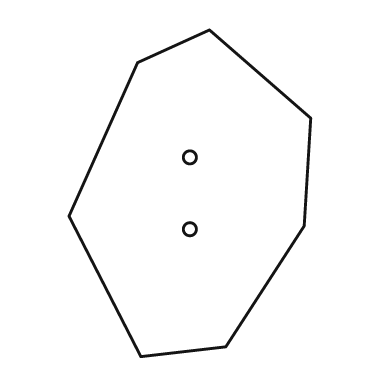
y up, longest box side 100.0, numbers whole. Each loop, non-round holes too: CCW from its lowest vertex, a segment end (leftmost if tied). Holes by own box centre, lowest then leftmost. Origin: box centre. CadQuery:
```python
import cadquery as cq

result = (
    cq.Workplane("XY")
    .moveTo(-15.0, -50.0)
    .lineTo(11.0, -47.0)
    .lineTo(35.0, -10.0)
    .lineTo(37.0, 23.0)
    .lineTo(6.0, 50.0)
    .lineTo(-16.0, 40.0)
    .lineTo(-37.0, -7.0)
    .close()
    .moveTo(0.0, -11.0)
    .circle(2.0)
    .moveTo(0.0, 11.0)
    .circle(2.0)
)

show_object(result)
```